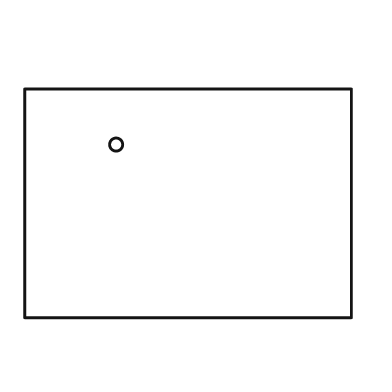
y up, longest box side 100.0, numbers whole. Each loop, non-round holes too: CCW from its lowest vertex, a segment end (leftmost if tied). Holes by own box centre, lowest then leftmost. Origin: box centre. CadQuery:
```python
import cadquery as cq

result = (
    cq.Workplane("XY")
    .moveTo(-50.0, -35.0)
    .lineTo(50.0, -35.0)
    .lineTo(50.0, 35.0)
    .lineTo(-50.0, 35.0)
    .close()
    .moveTo(-22.0, 18.0)
    .circle(2.0)
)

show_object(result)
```